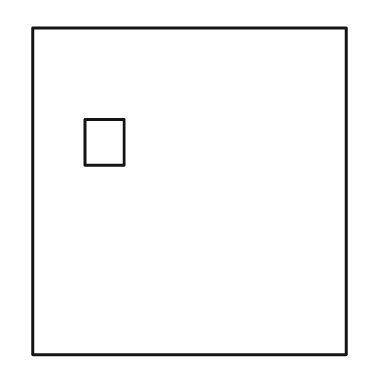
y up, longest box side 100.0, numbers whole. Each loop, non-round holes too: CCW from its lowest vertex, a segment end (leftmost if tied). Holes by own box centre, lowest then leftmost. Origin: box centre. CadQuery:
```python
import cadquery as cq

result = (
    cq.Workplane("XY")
    .moveTo(-48.0, -50.0)
    .lineTo(48.0, -50.0)
    .lineTo(48.0, 50.0)
    .lineTo(-48.0, 50.0)
    .close()
    .moveTo(-32.0, 8.0)
    .lineTo(-20.0, 8.0)
    .lineTo(-20.0, 22.0)
    .lineTo(-32.0, 22.0)
    .close()
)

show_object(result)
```